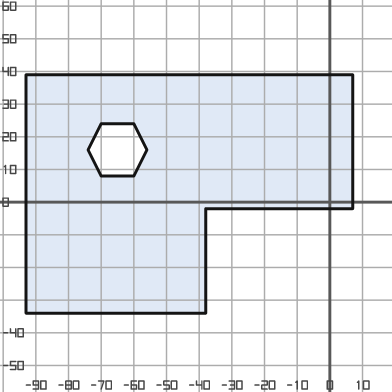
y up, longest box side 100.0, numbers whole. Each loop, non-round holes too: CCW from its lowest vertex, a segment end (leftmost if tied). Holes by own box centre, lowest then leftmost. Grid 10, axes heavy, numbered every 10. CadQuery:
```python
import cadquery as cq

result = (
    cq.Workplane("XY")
    .moveTo(-93.0, -34.0)
    .lineTo(-38.0, -34.0)
    .lineTo(-38.0, -2.0)
    .lineTo(7.0, -2.0)
    .lineTo(7.0, 39.0)
    .lineTo(-93.0, 39.0)
    .close()
    .moveTo(-70.0, 8.0)
    .lineTo(-60.0, 8.0)
    .lineTo(-56.0, 16.0)
    .lineTo(-60.0, 24.0)
    .lineTo(-70.0, 24.0)
    .lineTo(-74.0, 16.0)
    .close()
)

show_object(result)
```